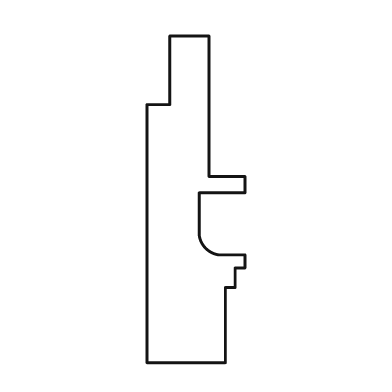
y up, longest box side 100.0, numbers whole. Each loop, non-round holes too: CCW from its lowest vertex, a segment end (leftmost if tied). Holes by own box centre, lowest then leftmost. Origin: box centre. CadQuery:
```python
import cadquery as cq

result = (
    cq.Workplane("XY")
    .moveTo(-15.0, -50.0)
    .lineTo(9.0, -50.0)
    .lineTo(9.0, -27.0)
    .lineTo(12.0, -27.0)
    .lineTo(12.0, -21.0)
    .lineTo(15.0, -21.0)
    .lineTo(15.0, -17.0)
    .lineTo(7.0, -17.0)
    .threePointArc((3.0, -15.0), (1.0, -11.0))
    .lineTo(1.0, 2.0)
    .lineTo(15.0, 2.0)
    .lineTo(15.0, 7.0)
    .lineTo(4.0, 7.0)
    .lineTo(4.0, 50.0)
    .lineTo(-8.0, 50.0)
    .lineTo(-8.0, 29.0)
    .lineTo(-15.0, 29.0)
    .close()
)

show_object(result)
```